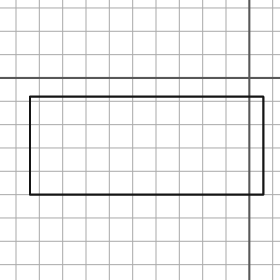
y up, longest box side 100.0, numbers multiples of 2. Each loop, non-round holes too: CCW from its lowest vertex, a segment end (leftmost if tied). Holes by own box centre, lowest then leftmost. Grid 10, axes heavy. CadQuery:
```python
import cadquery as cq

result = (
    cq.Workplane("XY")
    .moveTo(-94.0, -50.0)
    .lineTo(6.0, -50.0)
    .lineTo(6.0, -8.0)
    .lineTo(-94.0, -8.0)
    .close()
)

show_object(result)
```